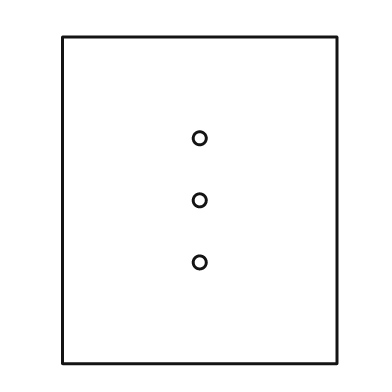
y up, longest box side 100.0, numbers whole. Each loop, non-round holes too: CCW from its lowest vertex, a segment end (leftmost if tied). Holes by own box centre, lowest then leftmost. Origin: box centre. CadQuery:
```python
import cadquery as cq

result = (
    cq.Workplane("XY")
    .moveTo(-42.0, -50.0)
    .lineTo(42.0, -50.0)
    .lineTo(42.0, 50.0)
    .lineTo(-42.0, 50.0)
    .close()
    .moveTo(0.0, -19.0)
    .circle(2.0)
    .moveTo(0.0, 0.0)
    .circle(2.0)
    .moveTo(0.0, 19.0)
    .circle(2.0)
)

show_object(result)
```